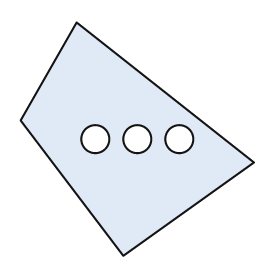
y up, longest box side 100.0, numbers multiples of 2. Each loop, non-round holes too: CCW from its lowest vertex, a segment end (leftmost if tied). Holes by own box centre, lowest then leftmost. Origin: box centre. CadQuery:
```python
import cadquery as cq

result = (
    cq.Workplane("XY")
    .moveTo(-6.0, -50.0)
    .lineTo(50.0, -10.0)
    .lineTo(-26.0, 50.0)
    .lineTo(-50.0, 8.0)
    .close()
    .moveTo(-18.0, 0.0)
    .circle(6.0)
    .moveTo(0.0, 0.0)
    .circle(6.0)
    .moveTo(18.0, 0.0)
    .circle(6.0)
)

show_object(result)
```